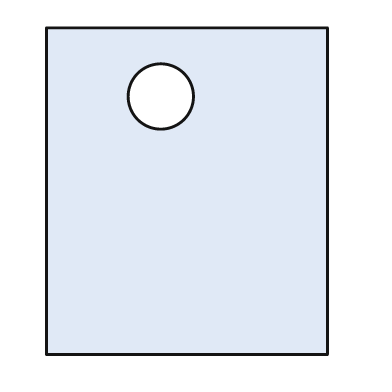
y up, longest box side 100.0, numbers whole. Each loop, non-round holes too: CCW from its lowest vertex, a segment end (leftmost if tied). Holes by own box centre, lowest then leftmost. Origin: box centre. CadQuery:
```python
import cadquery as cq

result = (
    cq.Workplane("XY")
    .moveTo(-43.0, -50.0)
    .lineTo(43.0, -50.0)
    .lineTo(43.0, 50.0)
    .lineTo(-43.0, 50.0)
    .close()
    .moveTo(-8.0, 29.0)
    .circle(10.0)
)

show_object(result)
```